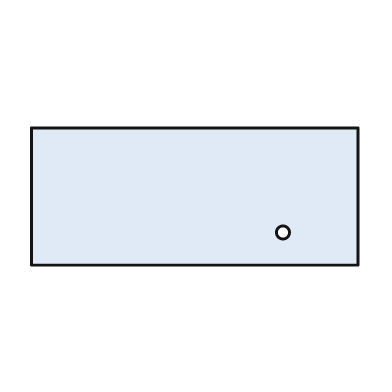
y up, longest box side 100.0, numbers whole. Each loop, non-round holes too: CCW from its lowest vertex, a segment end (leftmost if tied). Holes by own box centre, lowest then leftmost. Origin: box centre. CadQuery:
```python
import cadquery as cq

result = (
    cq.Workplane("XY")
    .moveTo(-50.0, -21.0)
    .lineTo(50.0, -21.0)
    .lineTo(50.0, 21.0)
    .lineTo(-50.0, 21.0)
    .close()
    .moveTo(27.0, -11.0)
    .circle(2.0)
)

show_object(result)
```